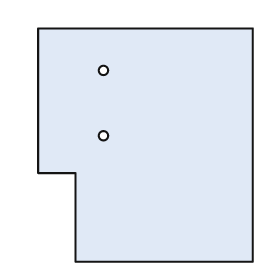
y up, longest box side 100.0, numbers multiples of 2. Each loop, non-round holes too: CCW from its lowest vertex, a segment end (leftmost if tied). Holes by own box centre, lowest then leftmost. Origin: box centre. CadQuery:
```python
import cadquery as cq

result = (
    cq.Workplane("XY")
    .moveTo(-30.0, -50.0)
    .lineTo(46.0, -50.0)
    .lineTo(46.0, 50.0)
    .lineTo(-46.0, 50.0)
    .lineTo(-46.0, -12.0)
    .lineTo(-30.0, -12.0)
    .close()
    .moveTo(-18.0, 4.0)
    .circle(2.0)
    .moveTo(-18.0, 32.0)
    .circle(2.0)
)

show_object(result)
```